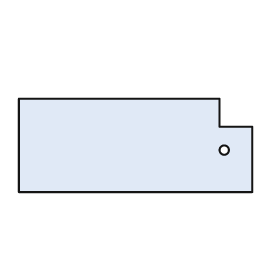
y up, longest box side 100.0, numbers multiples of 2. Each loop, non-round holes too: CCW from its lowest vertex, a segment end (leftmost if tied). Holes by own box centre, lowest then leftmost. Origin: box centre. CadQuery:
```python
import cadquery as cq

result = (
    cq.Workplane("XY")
    .moveTo(-50.0, -20.0)
    .lineTo(50.0, -20.0)
    .lineTo(50.0, 8.0)
    .lineTo(36.0, 8.0)
    .lineTo(36.0, 20.0)
    .lineTo(-50.0, 20.0)
    .close()
    .moveTo(38.0, -2.0)
    .circle(2.0)
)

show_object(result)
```